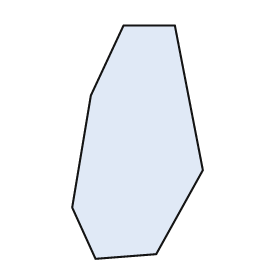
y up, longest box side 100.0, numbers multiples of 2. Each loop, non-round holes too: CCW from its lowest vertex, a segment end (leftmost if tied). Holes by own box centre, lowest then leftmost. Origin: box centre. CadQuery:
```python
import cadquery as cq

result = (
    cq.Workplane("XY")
    .moveTo(-18.0, -50.0)
    .lineTo(8.0, -48.0)
    .lineTo(28.0, -12.0)
    .lineTo(16.0, 50.0)
    .lineTo(-6.0, 50.0)
    .lineTo(-20.0, 20.0)
    .lineTo(-28.0, -28.0)
    .close()
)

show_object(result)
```